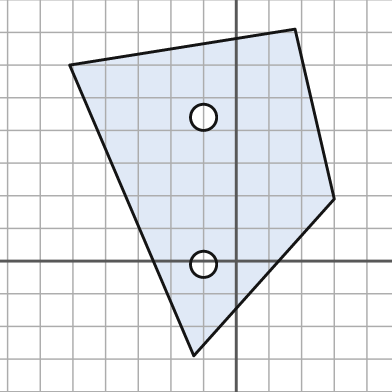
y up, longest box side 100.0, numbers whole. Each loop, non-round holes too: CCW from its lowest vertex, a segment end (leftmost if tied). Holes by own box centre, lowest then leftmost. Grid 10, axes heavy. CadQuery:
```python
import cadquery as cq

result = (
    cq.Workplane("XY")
    .moveTo(-13.0, -29.0)
    .lineTo(30.0, 19.0)
    .lineTo(18.0, 71.0)
    .lineTo(-51.0, 60.0)
    .close()
    .moveTo(-10.0, -1.0)
    .circle(4.0)
    .moveTo(-10.0, 44.0)
    .circle(4.0)
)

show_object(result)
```